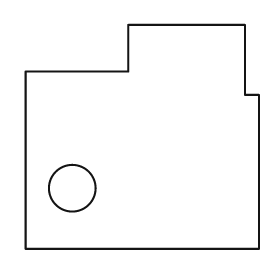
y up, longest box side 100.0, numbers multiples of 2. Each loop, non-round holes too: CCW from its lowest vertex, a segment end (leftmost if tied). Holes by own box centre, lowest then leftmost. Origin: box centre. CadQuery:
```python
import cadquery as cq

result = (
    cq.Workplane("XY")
    .moveTo(-50.0, -48.0)
    .lineTo(50.0, -48.0)
    .lineTo(50.0, 18.0)
    .lineTo(44.0, 18.0)
    .lineTo(44.0, 48.0)
    .lineTo(-6.0, 48.0)
    .lineTo(-6.0, 28.0)
    .lineTo(-50.0, 28.0)
    .close()
    .moveTo(-30.0, -22.0)
    .circle(10.0)
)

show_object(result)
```